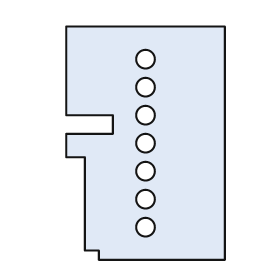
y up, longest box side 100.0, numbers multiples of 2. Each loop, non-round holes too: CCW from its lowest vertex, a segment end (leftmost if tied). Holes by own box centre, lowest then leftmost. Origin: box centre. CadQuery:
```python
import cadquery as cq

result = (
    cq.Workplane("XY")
    .moveTo(-20.0, -50.0)
    .lineTo(34.0, -50.0)
    .lineTo(34.0, 50.0)
    .lineTo(-34.0, 50.0)
    .lineTo(-34.0, 12.0)
    .lineTo(-14.0, 12.0)
    .lineTo(-14.0, 4.0)
    .lineTo(-34.0, 4.0)
    .lineTo(-34.0, -6.0)
    .lineTo(-26.0, -6.0)
    .lineTo(-26.0, -46.0)
    .lineTo(-20.0, -46.0)
    .close()
    .moveTo(0.0, -36.0)
    .circle(4.0)
    .moveTo(0.0, -24.0)
    .circle(4.0)
    .moveTo(0.0, -12.0)
    .circle(4.0)
    .moveTo(0.0, 0.0)
    .circle(4.0)
    .moveTo(0.0, 12.0)
    .circle(4.0)
    .moveTo(0.0, 24.0)
    .circle(4.0)
    .moveTo(0.0, 36.0)
    .circle(4.0)
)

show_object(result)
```